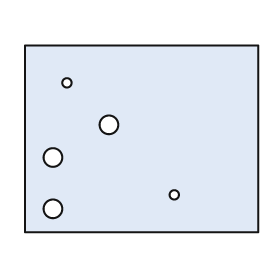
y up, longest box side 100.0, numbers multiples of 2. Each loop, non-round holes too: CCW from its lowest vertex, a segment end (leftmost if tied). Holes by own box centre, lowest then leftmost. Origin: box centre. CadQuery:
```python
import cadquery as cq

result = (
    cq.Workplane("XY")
    .moveTo(-50.0, -40.0)
    .lineTo(50.0, -40.0)
    .lineTo(50.0, 40.0)
    .lineTo(-50.0, 40.0)
    .close()
    .moveTo(-38.0, -30.0)
    .circle(4.0)
    .moveTo(14.0, -24.0)
    .circle(2.0)
    .moveTo(-38.0, -8.0)
    .circle(4.0)
    .moveTo(-14.0, 6.0)
    .circle(4.0)
    .moveTo(-32.0, 24.0)
    .circle(2.0)
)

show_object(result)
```